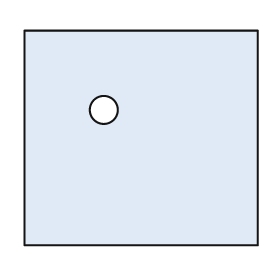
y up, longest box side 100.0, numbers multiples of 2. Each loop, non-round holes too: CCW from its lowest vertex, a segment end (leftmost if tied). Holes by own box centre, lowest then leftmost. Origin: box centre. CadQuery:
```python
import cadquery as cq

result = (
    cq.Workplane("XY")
    .moveTo(-50.0, -46.0)
    .lineTo(50.0, -46.0)
    .lineTo(50.0, 46.0)
    .lineTo(-50.0, 46.0)
    .close()
    .moveTo(-16.0, 12.0)
    .circle(6.0)
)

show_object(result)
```